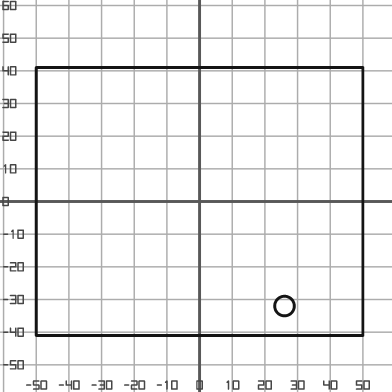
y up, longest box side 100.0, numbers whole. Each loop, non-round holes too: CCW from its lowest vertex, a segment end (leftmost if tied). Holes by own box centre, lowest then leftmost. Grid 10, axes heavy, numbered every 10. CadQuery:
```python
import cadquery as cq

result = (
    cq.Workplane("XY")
    .moveTo(-50.0, -41.0)
    .lineTo(50.0, -41.0)
    .lineTo(50.0, 41.0)
    .lineTo(-50.0, 41.0)
    .close()
    .moveTo(26.0, -32.0)
    .circle(3.0)
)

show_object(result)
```